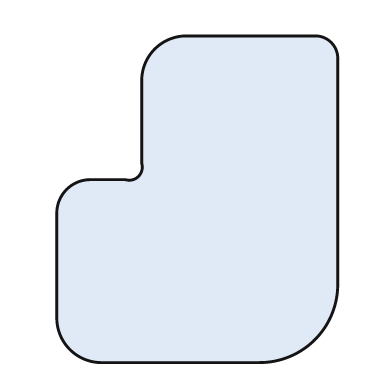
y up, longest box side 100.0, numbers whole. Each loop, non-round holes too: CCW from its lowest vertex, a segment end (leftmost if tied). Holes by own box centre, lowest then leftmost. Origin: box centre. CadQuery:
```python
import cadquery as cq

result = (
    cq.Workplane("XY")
    .moveTo(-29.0, -50.0)
    .lineTo(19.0, -50.0)
    .threePointArc((36.0, -43.0), (43.0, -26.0))
    .lineTo(43.0, 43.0)
    .threePointArc((41.0, 48.0), (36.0, 50.0))
    .lineTo(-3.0, 50.0)
    .threePointArc((-13.0, 46.0), (-17.0, 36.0))
    .lineTo(-17.0, 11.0)
    .threePointArc((-18.0, 7.0), (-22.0, 6.0))
    .lineTo(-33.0, 6.0)
    .threePointArc((-40.0, 3.0), (-43.0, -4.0))
    .lineTo(-43.0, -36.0)
    .threePointArc((-39.0, -46.0), (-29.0, -50.0))
    .close()
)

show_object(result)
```